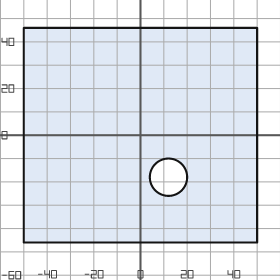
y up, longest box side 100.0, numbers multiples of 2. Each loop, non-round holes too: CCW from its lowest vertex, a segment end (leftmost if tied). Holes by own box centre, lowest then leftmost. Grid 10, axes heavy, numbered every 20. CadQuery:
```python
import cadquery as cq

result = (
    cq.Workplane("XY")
    .moveTo(-50.0, -46.0)
    .lineTo(50.0, -46.0)
    .lineTo(50.0, 46.0)
    .lineTo(-50.0, 46.0)
    .close()
    .moveTo(12.0, -18.0)
    .circle(8.0)
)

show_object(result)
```